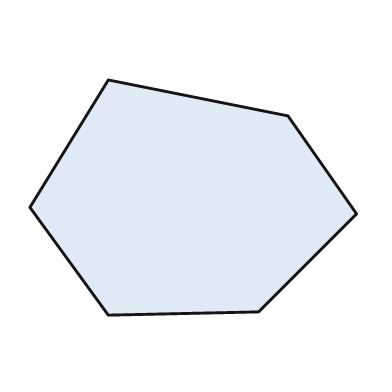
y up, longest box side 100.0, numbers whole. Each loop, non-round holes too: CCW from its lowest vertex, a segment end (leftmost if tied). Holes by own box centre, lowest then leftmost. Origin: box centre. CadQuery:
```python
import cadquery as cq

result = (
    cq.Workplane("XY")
    .moveTo(-26.0, -36.0)
    .lineTo(20.0, -35.0)
    .lineTo(50.0, -5.0)
    .lineTo(29.0, 25.0)
    .lineTo(-26.0, 36.0)
    .lineTo(-50.0, -3.0)
    .close()
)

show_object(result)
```